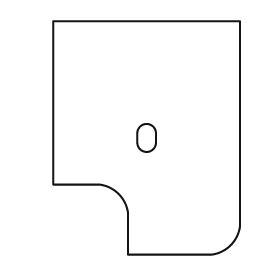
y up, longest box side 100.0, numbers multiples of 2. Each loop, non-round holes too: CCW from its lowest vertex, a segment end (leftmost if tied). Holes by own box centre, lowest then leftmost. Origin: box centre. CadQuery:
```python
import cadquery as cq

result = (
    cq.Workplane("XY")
    .moveTo(-8.0, -50.0)
    .lineTo(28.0, -50.0)
    .threePointArc((36.0, -46.0), (40.0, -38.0))
    .lineTo(40.0, 50.0)
    .lineTo(-40.0, 50.0)
    .lineTo(-40.0, -20.0)
    .lineTo(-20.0, -20.0)
    .threePointArc((-12.0, -24.0), (-8.0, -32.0))
    .close()
    .moveTo(-4.0, -2.0)
    .threePointArc((0.0, -6.0), (4.0, -2.0))
    .lineTo(4.0, 2.0)
    .threePointArc((0.0, 6.0), (-4.0, 2.0))
    .close()
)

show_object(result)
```